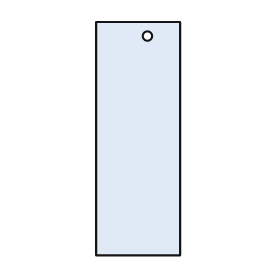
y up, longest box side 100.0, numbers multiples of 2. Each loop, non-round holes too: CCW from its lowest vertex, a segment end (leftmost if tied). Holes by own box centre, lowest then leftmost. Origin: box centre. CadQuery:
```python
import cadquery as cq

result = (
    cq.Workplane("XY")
    .moveTo(-18.0, -50.0)
    .lineTo(18.0, -50.0)
    .lineTo(18.0, 50.0)
    .lineTo(-18.0, 50.0)
    .close()
    .moveTo(4.0, 44.0)
    .circle(2.0)
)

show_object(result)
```